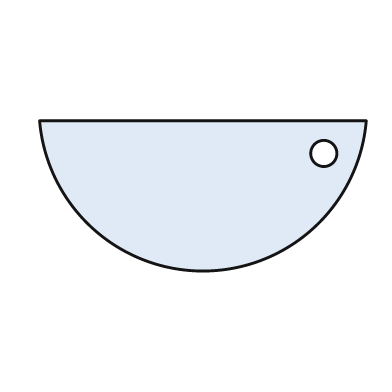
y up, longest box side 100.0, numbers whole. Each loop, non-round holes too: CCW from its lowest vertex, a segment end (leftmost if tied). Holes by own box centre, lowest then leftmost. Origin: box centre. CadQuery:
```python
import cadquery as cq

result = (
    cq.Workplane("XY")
    .moveTo(-50.0, 23.0)
    .threePointArc((0.0, -23.0), (50.0, 23.0))
    .close()
    .moveTo(37.0, 13.0)
    .circle(4.0)
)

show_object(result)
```